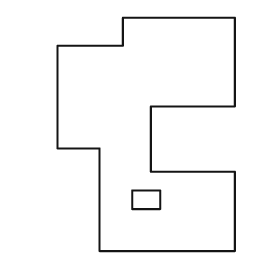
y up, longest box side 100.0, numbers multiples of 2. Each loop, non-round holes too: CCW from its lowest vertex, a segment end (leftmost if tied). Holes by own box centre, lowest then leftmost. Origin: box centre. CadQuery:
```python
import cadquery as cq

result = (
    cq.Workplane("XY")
    .moveTo(-20.0, -50.0)
    .lineTo(38.0, -50.0)
    .lineTo(38.0, -16.0)
    .lineTo(2.0, -16.0)
    .lineTo(2.0, 12.0)
    .lineTo(38.0, 12.0)
    .lineTo(38.0, 50.0)
    .lineTo(-10.0, 50.0)
    .lineTo(-10.0, 38.0)
    .lineTo(-38.0, 38.0)
    .lineTo(-38.0, -6.0)
    .lineTo(-20.0, -6.0)
    .close()
    .moveTo(-6.0, -32.0)
    .lineTo(6.0, -32.0)
    .lineTo(6.0, -24.0)
    .lineTo(-6.0, -24.0)
    .close()
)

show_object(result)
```